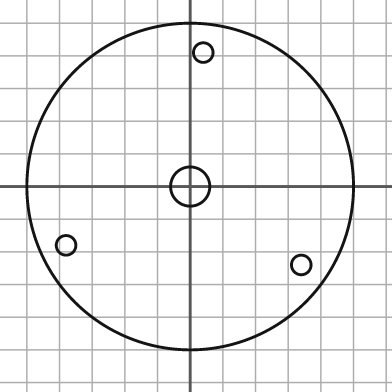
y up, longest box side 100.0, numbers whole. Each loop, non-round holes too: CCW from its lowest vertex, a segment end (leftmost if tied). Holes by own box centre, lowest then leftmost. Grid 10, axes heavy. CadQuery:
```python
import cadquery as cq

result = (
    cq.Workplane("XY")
    .moveTo(0.0, 0.0)
    .circle(50.0)
    .moveTo(34.0, -24.0)
    .circle(3.0)
    .moveTo(-38.0, -18.0)
    .circle(3.0)
    .moveTo(0.0, 0.0)
    .circle(6.0)
    .moveTo(4.0, 41.0)
    .circle(3.0)
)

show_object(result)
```